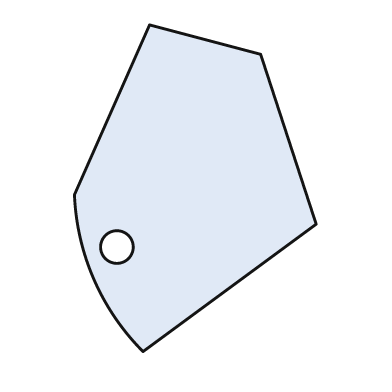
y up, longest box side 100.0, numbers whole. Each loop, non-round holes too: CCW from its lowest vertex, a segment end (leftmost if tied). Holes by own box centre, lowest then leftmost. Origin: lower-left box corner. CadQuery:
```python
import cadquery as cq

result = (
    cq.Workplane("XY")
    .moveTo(21.0, 0.0)
    .lineTo(74.0, 39.0)
    .lineTo(57.0, 91.0)
    .lineTo(23.0, 100.0)
    .lineTo(0.0, 48.0)
    .threePointArc((6.0, 22.0), (21.0, 0.0))
    .close()
    .moveTo(13.0, 32.0)
    .circle(5.0)
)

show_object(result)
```